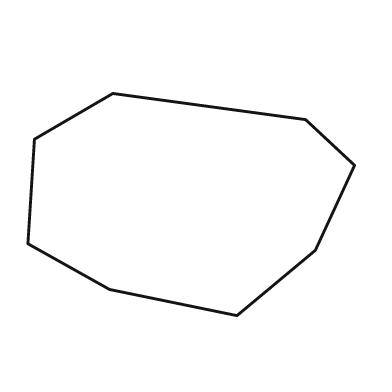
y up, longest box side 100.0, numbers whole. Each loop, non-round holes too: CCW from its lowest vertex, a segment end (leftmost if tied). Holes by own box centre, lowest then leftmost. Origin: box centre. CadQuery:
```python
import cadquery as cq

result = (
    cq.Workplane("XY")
    .moveTo(14.0, -34.0)
    .lineTo(38.0, -14.0)
    .lineTo(50.0, 12.0)
    .lineTo(35.0, 26.0)
    .lineTo(-24.0, 34.0)
    .lineTo(-48.0, 20.0)
    .lineTo(-50.0, -12.0)
    .lineTo(-25.0, -26.0)
    .close()
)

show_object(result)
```